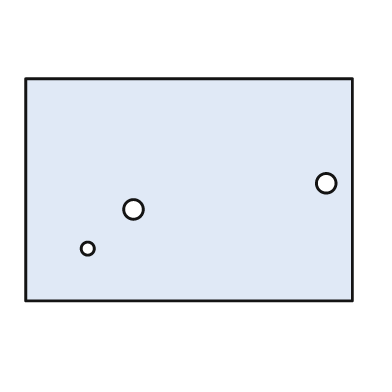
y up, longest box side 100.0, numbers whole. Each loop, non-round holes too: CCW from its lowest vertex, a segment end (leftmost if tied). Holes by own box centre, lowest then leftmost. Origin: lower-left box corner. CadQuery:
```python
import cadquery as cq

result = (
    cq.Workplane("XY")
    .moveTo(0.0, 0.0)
    .lineTo(100.0, 0.0)
    .lineTo(100.0, 68.0)
    .lineTo(0.0, 68.0)
    .close()
    .moveTo(19.0, 16.0)
    .circle(2.0)
    .moveTo(33.0, 28.0)
    .circle(3.0)
    .moveTo(92.0, 36.0)
    .circle(3.0)
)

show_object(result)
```